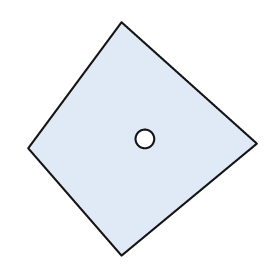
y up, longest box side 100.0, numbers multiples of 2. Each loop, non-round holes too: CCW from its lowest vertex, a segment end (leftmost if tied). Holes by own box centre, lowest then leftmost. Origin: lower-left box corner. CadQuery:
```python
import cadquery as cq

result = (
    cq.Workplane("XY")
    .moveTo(40.0, 0.0)
    .lineTo(98.0, 48.0)
    .lineTo(40.0, 100.0)
    .lineTo(0.0, 46.0)
    .close()
    .moveTo(50.0, 50.0)
    .circle(4.0)
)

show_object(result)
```